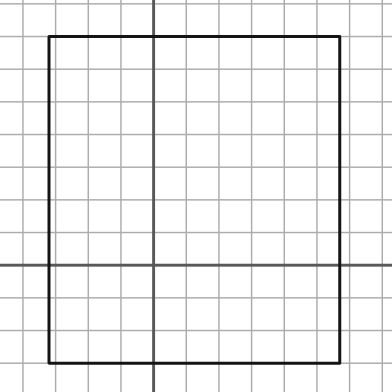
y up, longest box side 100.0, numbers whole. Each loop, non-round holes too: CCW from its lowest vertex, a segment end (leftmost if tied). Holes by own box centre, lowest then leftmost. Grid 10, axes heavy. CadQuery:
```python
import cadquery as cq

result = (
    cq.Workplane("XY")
    .moveTo(-32.0, -30.0)
    .lineTo(57.0, -30.0)
    .lineTo(57.0, 70.0)
    .lineTo(-32.0, 70.0)
    .close()
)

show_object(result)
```